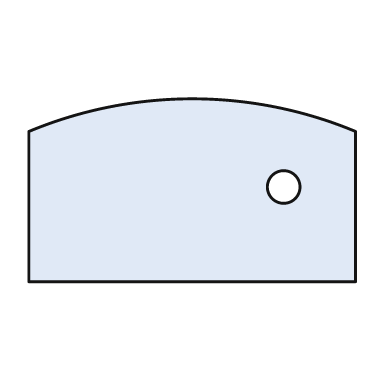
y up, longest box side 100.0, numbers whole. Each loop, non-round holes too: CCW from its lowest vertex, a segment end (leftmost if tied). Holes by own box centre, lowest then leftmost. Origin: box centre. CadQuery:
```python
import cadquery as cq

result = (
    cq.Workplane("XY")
    .moveTo(-50.0, -28.0)
    .lineTo(50.0, -28.0)
    .lineTo(50.0, 18.0)
    .threePointArc((0.0, 28.0), (-50.0, 18.0))
    .close()
    .moveTo(28.0, 1.0)
    .circle(5.0)
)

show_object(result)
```